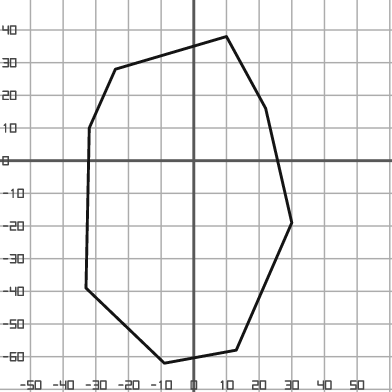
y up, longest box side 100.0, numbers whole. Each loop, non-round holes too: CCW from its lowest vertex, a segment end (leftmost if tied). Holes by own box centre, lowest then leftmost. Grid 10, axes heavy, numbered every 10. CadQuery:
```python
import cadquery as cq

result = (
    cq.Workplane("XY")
    .moveTo(-9.0, -62.0)
    .lineTo(13.0, -58.0)
    .lineTo(30.0, -19.0)
    .lineTo(22.0, 16.0)
    .lineTo(10.0, 38.0)
    .lineTo(-24.0, 28.0)
    .lineTo(-32.0, 10.0)
    .lineTo(-33.0, -39.0)
    .close()
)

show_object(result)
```